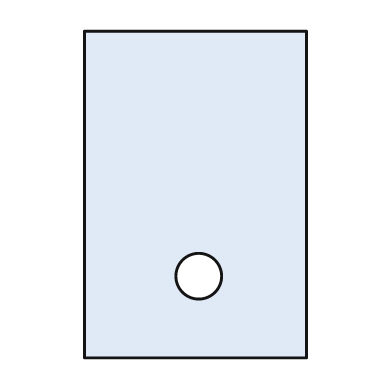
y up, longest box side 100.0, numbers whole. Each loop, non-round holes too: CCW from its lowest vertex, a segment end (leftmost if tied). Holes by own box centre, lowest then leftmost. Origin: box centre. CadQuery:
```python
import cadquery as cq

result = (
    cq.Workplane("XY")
    .moveTo(-34.0, -50.0)
    .lineTo(34.0, -50.0)
    .lineTo(34.0, 50.0)
    .lineTo(-34.0, 50.0)
    .close()
    .moveTo(1.0, -25.0)
    .circle(7.0)
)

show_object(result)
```